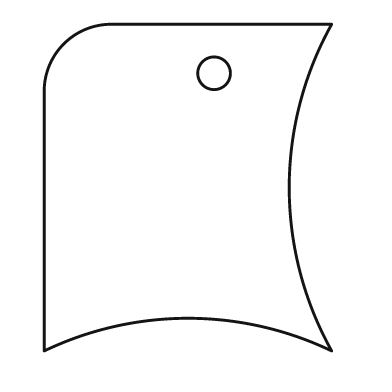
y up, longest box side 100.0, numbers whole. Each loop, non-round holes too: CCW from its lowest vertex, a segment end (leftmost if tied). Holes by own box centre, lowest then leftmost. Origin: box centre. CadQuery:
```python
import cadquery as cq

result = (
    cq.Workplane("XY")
    .moveTo(-44.0, -50.0)
    .threePointArc((0.0, -40.0), (44.0, -50.0))
    .threePointArc((31.0, 0.0), (44.0, 50.0))
    .lineTo(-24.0, 50.0)
    .threePointArc((-38.0, 44.0), (-44.0, 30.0))
    .close()
    .moveTo(8.0, 35.0)
    .circle(5.0)
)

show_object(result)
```